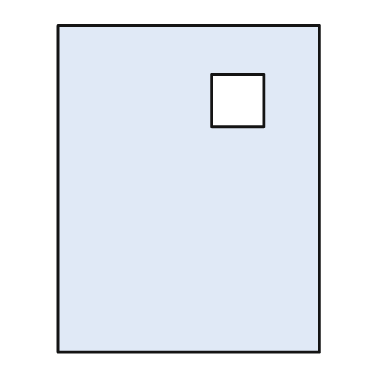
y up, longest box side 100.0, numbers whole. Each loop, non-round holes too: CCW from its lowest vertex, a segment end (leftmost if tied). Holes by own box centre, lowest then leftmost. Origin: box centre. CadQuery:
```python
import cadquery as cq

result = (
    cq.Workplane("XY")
    .moveTo(-40.0, -50.0)
    .lineTo(40.0, -50.0)
    .lineTo(40.0, 50.0)
    .lineTo(-40.0, 50.0)
    .close()
    .moveTo(7.0, 19.0)
    .lineTo(23.0, 19.0)
    .lineTo(23.0, 35.0)
    .lineTo(7.0, 35.0)
    .close()
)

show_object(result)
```